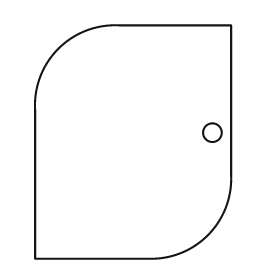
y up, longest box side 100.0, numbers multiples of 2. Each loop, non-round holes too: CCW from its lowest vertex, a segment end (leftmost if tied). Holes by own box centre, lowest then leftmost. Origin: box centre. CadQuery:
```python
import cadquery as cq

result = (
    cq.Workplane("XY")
    .moveTo(-42.0, -50.0)
    .lineTo(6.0, -50.0)
    .threePointArc((32.0, -40.0), (42.0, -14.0))
    .lineTo(42.0, 50.0)
    .lineTo(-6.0, 50.0)
    .threePointArc((-32.0, 40.0), (-42.0, 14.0))
    .close()
    .moveTo(34.0, 4.0)
    .circle(4.0)
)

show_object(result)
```